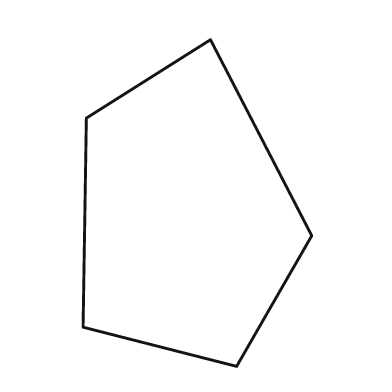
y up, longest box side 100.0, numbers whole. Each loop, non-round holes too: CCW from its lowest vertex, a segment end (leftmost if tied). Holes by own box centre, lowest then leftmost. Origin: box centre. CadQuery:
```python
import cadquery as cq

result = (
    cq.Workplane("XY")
    .moveTo(12.0, -50.0)
    .lineTo(35.0, -10.0)
    .lineTo(4.0, 50.0)
    .lineTo(-34.0, 26.0)
    .lineTo(-35.0, -38.0)
    .close()
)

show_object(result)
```